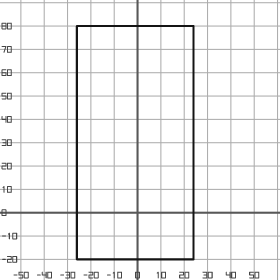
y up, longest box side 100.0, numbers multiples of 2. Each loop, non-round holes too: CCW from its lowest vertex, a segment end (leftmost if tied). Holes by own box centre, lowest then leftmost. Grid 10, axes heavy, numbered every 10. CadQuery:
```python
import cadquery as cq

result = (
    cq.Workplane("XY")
    .moveTo(-26.0, -20.0)
    .lineTo(24.0, -20.0)
    .lineTo(24.0, 80.0)
    .lineTo(-26.0, 80.0)
    .close()
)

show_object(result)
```